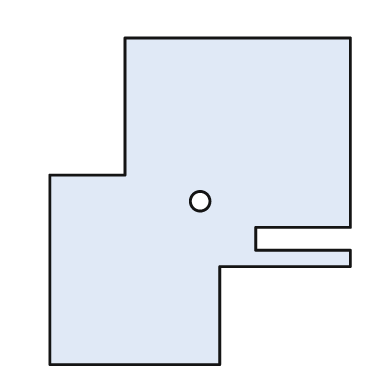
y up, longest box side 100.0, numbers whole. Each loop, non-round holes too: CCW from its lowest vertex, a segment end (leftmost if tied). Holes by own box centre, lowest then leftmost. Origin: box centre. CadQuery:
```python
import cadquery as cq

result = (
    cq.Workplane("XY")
    .moveTo(-46.0, -50.0)
    .lineTo(6.0, -50.0)
    .lineTo(6.0, -20.0)
    .lineTo(46.0, -20.0)
    .lineTo(46.0, -15.0)
    .lineTo(17.0, -15.0)
    .lineTo(17.0, -8.0)
    .lineTo(46.0, -8.0)
    .lineTo(46.0, 50.0)
    .lineTo(-23.0, 50.0)
    .lineTo(-23.0, 8.0)
    .lineTo(-46.0, 8.0)
    .close()
    .moveTo(0.0, 0.0)
    .circle(3.0)
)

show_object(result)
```